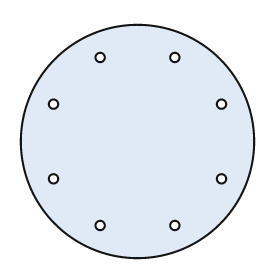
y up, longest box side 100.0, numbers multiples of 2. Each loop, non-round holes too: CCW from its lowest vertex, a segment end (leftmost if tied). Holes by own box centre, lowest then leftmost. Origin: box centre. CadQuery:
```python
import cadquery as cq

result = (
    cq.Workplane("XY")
    .moveTo(0.0, 0.0)
    .circle(50.0)
    .moveTo(-16.0, -36.0)
    .circle(2.0)
    .moveTo(16.0, -36.0)
    .circle(2.0)
    .moveTo(-36.0, -16.0)
    .circle(2.0)
    .moveTo(36.0, -16.0)
    .circle(2.0)
    .moveTo(-36.0, 16.0)
    .circle(2.0)
    .moveTo(36.0, 16.0)
    .circle(2.0)
    .moveTo(-16.0, 36.0)
    .circle(2.0)
    .moveTo(16.0, 36.0)
    .circle(2.0)
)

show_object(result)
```